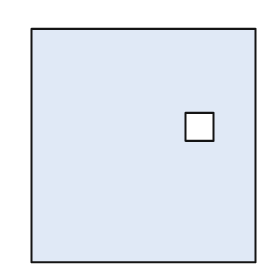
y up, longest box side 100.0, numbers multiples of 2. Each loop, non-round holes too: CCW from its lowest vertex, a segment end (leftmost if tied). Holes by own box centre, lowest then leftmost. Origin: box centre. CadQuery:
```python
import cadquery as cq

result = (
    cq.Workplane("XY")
    .moveTo(-48.0, -50.0)
    .lineTo(48.0, -50.0)
    .lineTo(48.0, 50.0)
    .lineTo(-48.0, 50.0)
    .close()
    .moveTo(18.0, 2.0)
    .lineTo(30.0, 2.0)
    .lineTo(30.0, 14.0)
    .lineTo(18.0, 14.0)
    .close()
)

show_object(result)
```